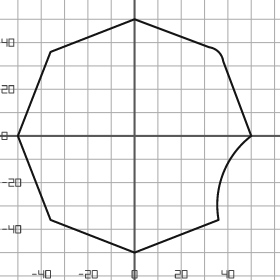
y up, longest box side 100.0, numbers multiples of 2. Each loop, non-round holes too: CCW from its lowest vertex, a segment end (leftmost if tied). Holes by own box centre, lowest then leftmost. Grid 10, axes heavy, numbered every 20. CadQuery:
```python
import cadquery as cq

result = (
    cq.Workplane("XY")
    .moveTo(0.0, -50.0)
    .lineTo(36.0, -36.0)
    .threePointArc((38.0, -16.0), (50.0, 0.0))
    .lineTo(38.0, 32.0)
    .threePointArc((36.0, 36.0), (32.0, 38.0))
    .lineTo(0.0, 50.0)
    .lineTo(-36.0, 36.0)
    .lineTo(-50.0, 0.0)
    .lineTo(-36.0, -36.0)
    .close()
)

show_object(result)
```